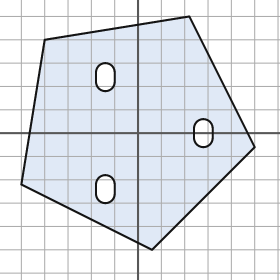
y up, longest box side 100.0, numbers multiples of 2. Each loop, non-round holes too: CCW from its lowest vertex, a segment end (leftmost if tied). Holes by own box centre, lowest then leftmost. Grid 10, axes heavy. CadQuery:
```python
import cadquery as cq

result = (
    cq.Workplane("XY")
    .moveTo(6.0, -50.0)
    .lineTo(50.0, -6.0)
    .lineTo(22.0, 50.0)
    .lineTo(-40.0, 40.0)
    .lineTo(-50.0, -22.0)
    .close()
    .moveTo(-18.0, -26.0)
    .threePointArc((-14.0, -30.0), (-10.0, -26.0))
    .lineTo(-10.0, -22.0)
    .threePointArc((-14.0, -18.0), (-18.0, -22.0))
    .close()
    .moveTo(24.0, -2.0)
    .threePointArc((28.0, -6.0), (32.0, -2.0))
    .lineTo(32.0, 2.0)
    .threePointArc((28.0, 6.0), (24.0, 2.0))
    .close()
    .moveTo(-18.0, 22.0)
    .threePointArc((-14.0, 18.0), (-10.0, 22.0))
    .lineTo(-10.0, 26.0)
    .threePointArc((-14.0, 30.0), (-18.0, 26.0))
    .close()
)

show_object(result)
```